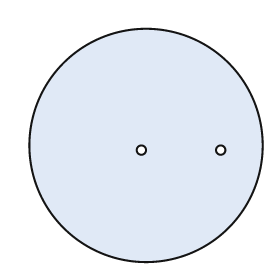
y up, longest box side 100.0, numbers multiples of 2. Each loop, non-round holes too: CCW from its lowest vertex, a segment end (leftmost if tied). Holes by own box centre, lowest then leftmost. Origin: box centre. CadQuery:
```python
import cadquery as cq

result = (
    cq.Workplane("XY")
    .moveTo(0.0, 0.0)
    .circle(50.0)
    .moveTo(-2.0, -2.0)
    .circle(2.0)
    .moveTo(32.0, -2.0)
    .circle(2.0)
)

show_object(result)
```